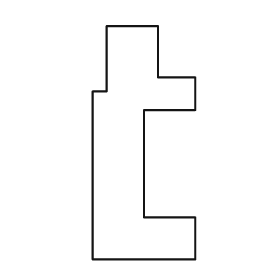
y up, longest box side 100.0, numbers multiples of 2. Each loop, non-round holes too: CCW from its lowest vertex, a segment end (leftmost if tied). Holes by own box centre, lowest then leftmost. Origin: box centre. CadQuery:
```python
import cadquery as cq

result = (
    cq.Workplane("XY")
    .moveTo(-22.0, -50.0)
    .lineTo(22.0, -50.0)
    .lineTo(22.0, -32.0)
    .lineTo(0.0, -32.0)
    .lineTo(0.0, 14.0)
    .lineTo(22.0, 14.0)
    .lineTo(22.0, 28.0)
    .lineTo(6.0, 28.0)
    .lineTo(6.0, 50.0)
    .lineTo(-16.0, 50.0)
    .lineTo(-16.0, 22.0)
    .lineTo(-22.0, 22.0)
    .close()
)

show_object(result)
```